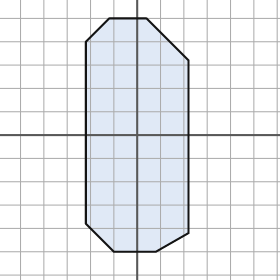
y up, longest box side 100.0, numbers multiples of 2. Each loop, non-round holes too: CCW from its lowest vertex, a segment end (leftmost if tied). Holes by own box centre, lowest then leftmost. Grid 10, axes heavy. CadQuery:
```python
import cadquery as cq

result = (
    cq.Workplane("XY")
    .moveTo(-10.0, -50.0)
    .lineTo(8.0, -50.0)
    .lineTo(22.0, -42.0)
    .lineTo(22.0, 32.0)
    .lineTo(4.0, 50.0)
    .lineTo(-12.0, 50.0)
    .lineTo(-22.0, 40.0)
    .lineTo(-22.0, -38.0)
    .close()
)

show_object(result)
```